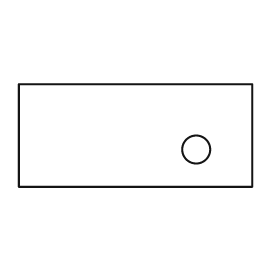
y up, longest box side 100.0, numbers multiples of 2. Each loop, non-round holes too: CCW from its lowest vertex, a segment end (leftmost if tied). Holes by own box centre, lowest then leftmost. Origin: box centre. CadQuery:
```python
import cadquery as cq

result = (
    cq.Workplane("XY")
    .moveTo(-50.0, -22.0)
    .lineTo(50.0, -22.0)
    .lineTo(50.0, 22.0)
    .lineTo(-50.0, 22.0)
    .close()
    .moveTo(26.0, -6.0)
    .circle(6.0)
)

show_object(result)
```